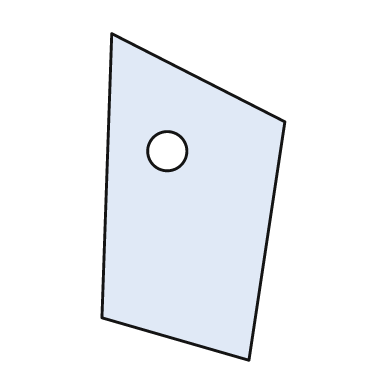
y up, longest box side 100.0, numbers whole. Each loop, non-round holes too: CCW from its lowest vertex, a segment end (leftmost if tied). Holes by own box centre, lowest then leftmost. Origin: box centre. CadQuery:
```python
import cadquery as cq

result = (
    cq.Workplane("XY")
    .moveTo(17.0, -50.0)
    .lineTo(28.0, 23.0)
    .lineTo(-25.0, 50.0)
    .lineTo(-28.0, -37.0)
    .close()
    .moveTo(-8.0, 14.0)
    .circle(6.0)
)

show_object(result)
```